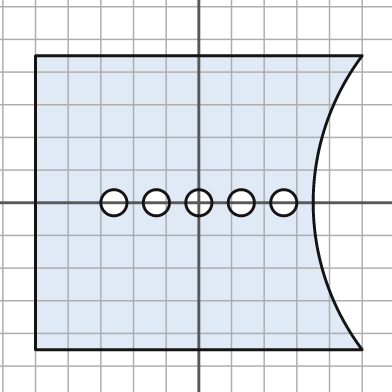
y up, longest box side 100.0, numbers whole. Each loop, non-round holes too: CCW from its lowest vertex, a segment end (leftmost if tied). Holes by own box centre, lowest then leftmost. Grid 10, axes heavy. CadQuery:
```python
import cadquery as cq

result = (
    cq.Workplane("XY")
    .moveTo(-50.0, -45.0)
    .lineTo(50.0, -45.0)
    .threePointArc((35.0, 0.0), (50.0, 45.0))
    .lineTo(-50.0, 45.0)
    .close()
    .moveTo(-26.0, 0.0)
    .circle(4.0)
    .moveTo(-13.0, 0.0)
    .circle(4.0)
    .moveTo(0.0, 0.0)
    .circle(4.0)
    .moveTo(13.0, 0.0)
    .circle(4.0)
    .moveTo(26.0, 0.0)
    .circle(4.0)
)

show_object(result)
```